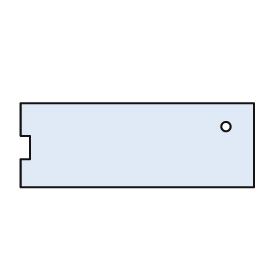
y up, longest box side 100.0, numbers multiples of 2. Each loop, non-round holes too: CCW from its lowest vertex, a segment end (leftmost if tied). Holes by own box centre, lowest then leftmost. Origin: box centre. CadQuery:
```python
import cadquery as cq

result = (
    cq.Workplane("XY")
    .moveTo(-50.0, -18.0)
    .lineTo(50.0, -18.0)
    .lineTo(50.0, 18.0)
    .lineTo(-50.0, 18.0)
    .lineTo(-50.0, 4.0)
    .lineTo(-46.0, 4.0)
    .lineTo(-46.0, -6.0)
    .lineTo(-50.0, -6.0)
    .close()
    .moveTo(38.0, 8.0)
    .circle(2.0)
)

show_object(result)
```